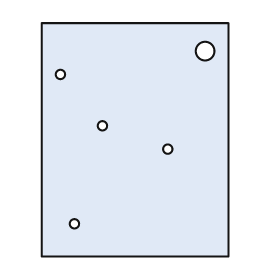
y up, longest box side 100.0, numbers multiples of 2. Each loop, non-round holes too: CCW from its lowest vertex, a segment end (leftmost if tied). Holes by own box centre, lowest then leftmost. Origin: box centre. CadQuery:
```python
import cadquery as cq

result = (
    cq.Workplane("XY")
    .moveTo(-40.0, -50.0)
    .lineTo(40.0, -50.0)
    .lineTo(40.0, 50.0)
    .lineTo(-40.0, 50.0)
    .close()
    .moveTo(-26.0, -36.0)
    .circle(2.0)
    .moveTo(14.0, -4.0)
    .circle(2.0)
    .moveTo(-14.0, 6.0)
    .circle(2.0)
    .moveTo(-32.0, 28.0)
    .circle(2.0)
    .moveTo(30.0, 38.0)
    .circle(4.0)
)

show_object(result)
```